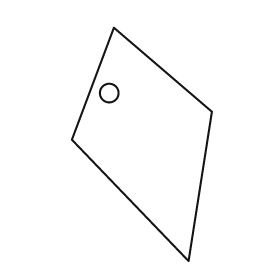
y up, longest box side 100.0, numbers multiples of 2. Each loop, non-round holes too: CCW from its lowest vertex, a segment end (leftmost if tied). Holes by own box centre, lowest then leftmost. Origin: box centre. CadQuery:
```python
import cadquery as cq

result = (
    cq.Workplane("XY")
    .moveTo(20.0, -50.0)
    .lineTo(30.0, 14.0)
    .lineTo(-12.0, 50.0)
    .lineTo(-30.0, 2.0)
    .close()
    .moveTo(-14.0, 22.0)
    .circle(4.0)
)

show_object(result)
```